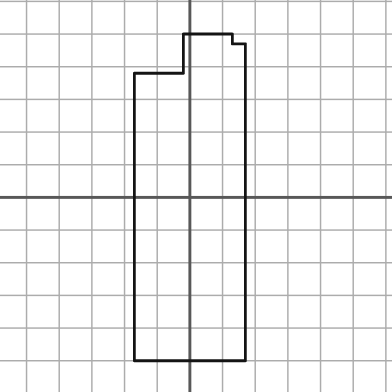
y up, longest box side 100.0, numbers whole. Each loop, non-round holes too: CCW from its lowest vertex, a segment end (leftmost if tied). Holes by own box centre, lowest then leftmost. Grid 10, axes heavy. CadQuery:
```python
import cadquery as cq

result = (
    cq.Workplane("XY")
    .moveTo(-17.0, -50.0)
    .lineTo(17.0, -50.0)
    .lineTo(17.0, 47.0)
    .lineTo(13.0, 47.0)
    .lineTo(13.0, 50.0)
    .lineTo(-2.0, 50.0)
    .lineTo(-2.0, 38.0)
    .lineTo(-17.0, 38.0)
    .close()
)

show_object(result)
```